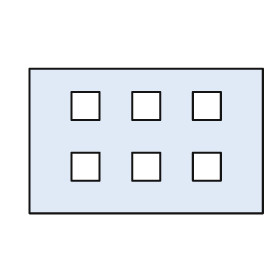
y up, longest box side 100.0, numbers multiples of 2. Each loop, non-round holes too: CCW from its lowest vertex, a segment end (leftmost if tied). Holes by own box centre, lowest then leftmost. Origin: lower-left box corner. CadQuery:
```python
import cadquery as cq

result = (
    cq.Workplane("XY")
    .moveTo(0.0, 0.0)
    .lineTo(100.0, 0.0)
    .lineTo(100.0, 62.0)
    .lineTo(0.0, 62.0)
    .close()
    .moveTo(18.0, 14.0)
    .lineTo(30.0, 14.0)
    .lineTo(30.0, 26.0)
    .lineTo(18.0, 26.0)
    .close()
    .moveTo(44.0, 14.0)
    .lineTo(56.0, 14.0)
    .lineTo(56.0, 26.0)
    .lineTo(44.0, 26.0)
    .close()
    .moveTo(70.0, 14.0)
    .lineTo(82.0, 14.0)
    .lineTo(82.0, 26.0)
    .lineTo(70.0, 26.0)
    .close()
    .moveTo(18.0, 40.0)
    .lineTo(30.0, 40.0)
    .lineTo(30.0, 52.0)
    .lineTo(18.0, 52.0)
    .close()
    .moveTo(44.0, 40.0)
    .lineTo(56.0, 40.0)
    .lineTo(56.0, 52.0)
    .lineTo(44.0, 52.0)
    .close()
    .moveTo(70.0, 40.0)
    .lineTo(82.0, 40.0)
    .lineTo(82.0, 52.0)
    .lineTo(70.0, 52.0)
    .close()
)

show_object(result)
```